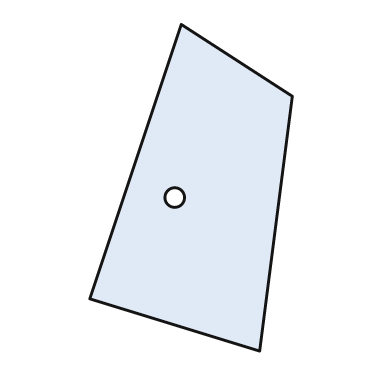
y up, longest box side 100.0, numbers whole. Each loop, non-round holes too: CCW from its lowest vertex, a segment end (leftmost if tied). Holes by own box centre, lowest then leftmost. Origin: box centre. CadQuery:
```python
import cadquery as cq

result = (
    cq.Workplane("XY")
    .moveTo(21.0, -50.0)
    .lineTo(31.0, 28.0)
    .lineTo(-3.0, 50.0)
    .lineTo(-31.0, -34.0)
    .close()
    .moveTo(-5.0, -3.0)
    .circle(3.0)
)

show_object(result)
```